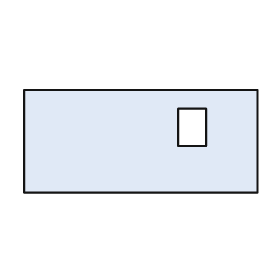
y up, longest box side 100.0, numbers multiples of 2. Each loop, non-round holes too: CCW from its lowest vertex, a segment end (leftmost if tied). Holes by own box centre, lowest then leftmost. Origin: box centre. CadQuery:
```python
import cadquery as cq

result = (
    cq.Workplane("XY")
    .moveTo(-50.0, -22.0)
    .lineTo(50.0, -22.0)
    .lineTo(50.0, 22.0)
    .lineTo(-50.0, 22.0)
    .close()
    .moveTo(16.0, -2.0)
    .lineTo(28.0, -2.0)
    .lineTo(28.0, 14.0)
    .lineTo(16.0, 14.0)
    .close()
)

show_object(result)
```